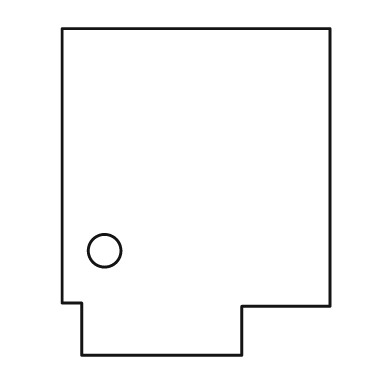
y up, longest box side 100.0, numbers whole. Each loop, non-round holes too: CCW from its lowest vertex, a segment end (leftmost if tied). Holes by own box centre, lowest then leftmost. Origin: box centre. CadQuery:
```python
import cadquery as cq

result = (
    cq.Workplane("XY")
    .moveTo(-35.0, -50.0)
    .lineTo(14.0, -50.0)
    .lineTo(14.0, -35.0)
    .lineTo(41.0, -35.0)
    .lineTo(41.0, 50.0)
    .lineTo(-41.0, 50.0)
    .lineTo(-41.0, -34.0)
    .lineTo(-35.0, -34.0)
    .close()
    .moveTo(-28.0, -18.0)
    .circle(5.0)
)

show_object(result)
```